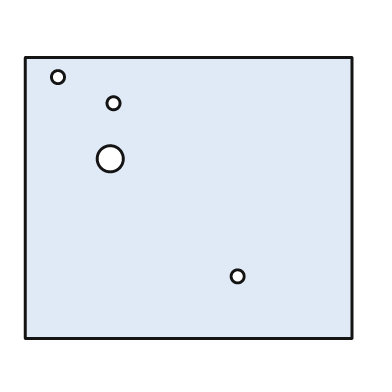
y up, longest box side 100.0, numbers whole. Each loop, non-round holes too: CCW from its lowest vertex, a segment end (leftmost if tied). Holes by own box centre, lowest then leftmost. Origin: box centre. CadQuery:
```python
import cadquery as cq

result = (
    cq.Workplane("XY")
    .moveTo(-50.0, -43.0)
    .lineTo(50.0, -43.0)
    .lineTo(50.0, 43.0)
    .lineTo(-50.0, 43.0)
    .close()
    .moveTo(15.0, -24.0)
    .circle(2.0)
    .moveTo(-24.0, 12.0)
    .circle(4.0)
    .moveTo(-23.0, 29.0)
    .circle(2.0)
    .moveTo(-40.0, 37.0)
    .circle(2.0)
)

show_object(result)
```